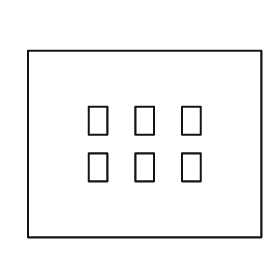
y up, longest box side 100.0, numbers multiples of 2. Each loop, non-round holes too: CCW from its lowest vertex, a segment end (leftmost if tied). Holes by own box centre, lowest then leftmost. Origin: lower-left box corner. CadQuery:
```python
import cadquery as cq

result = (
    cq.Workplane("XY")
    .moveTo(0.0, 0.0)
    .lineTo(100.0, 0.0)
    .lineTo(100.0, 80.0)
    .lineTo(0.0, 80.0)
    .close()
    .moveTo(26.0, 24.0)
    .lineTo(34.0, 24.0)
    .lineTo(34.0, 36.0)
    .lineTo(26.0, 36.0)
    .close()
    .moveTo(46.0, 24.0)
    .lineTo(54.0, 24.0)
    .lineTo(54.0, 36.0)
    .lineTo(46.0, 36.0)
    .close()
    .moveTo(66.0, 24.0)
    .lineTo(74.0, 24.0)
    .lineTo(74.0, 36.0)
    .lineTo(66.0, 36.0)
    .close()
    .moveTo(26.0, 44.0)
    .lineTo(34.0, 44.0)
    .lineTo(34.0, 56.0)
    .lineTo(26.0, 56.0)
    .close()
    .moveTo(46.0, 44.0)
    .lineTo(54.0, 44.0)
    .lineTo(54.0, 56.0)
    .lineTo(46.0, 56.0)
    .close()
    .moveTo(66.0, 44.0)
    .lineTo(74.0, 44.0)
    .lineTo(74.0, 56.0)
    .lineTo(66.0, 56.0)
    .close()
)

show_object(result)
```